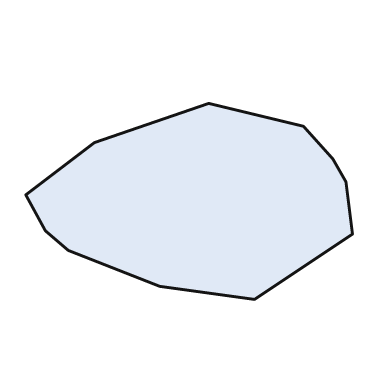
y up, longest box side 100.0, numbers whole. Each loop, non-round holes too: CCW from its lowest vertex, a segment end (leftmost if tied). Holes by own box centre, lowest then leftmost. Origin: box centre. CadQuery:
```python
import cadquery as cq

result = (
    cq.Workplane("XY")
    .moveTo(20.0, -30.0)
    .lineTo(50.0, -10.0)
    .lineTo(48.0, 6.0)
    .lineTo(44.0, 13.0)
    .lineTo(35.0, 23.0)
    .lineTo(6.0, 30.0)
    .lineTo(-29.0, 18.0)
    .lineTo(-50.0, 2.0)
    .lineTo(-44.0, -9.0)
    .lineTo(-37.0, -15.0)
    .lineTo(-9.0, -26.0)
    .close()
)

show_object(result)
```